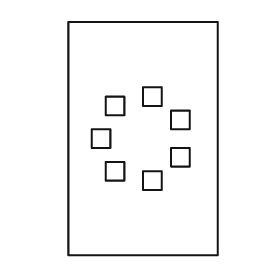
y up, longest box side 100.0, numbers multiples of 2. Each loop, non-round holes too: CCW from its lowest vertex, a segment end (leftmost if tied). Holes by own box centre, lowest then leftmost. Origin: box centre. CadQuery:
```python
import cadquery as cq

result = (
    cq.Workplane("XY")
    .moveTo(-32.0, -50.0)
    .lineTo(32.0, -50.0)
    .lineTo(32.0, 50.0)
    .lineTo(-32.0, 50.0)
    .close()
    .moveTo(0.0, -22.0)
    .lineTo(8.0, -22.0)
    .lineTo(8.0, -14.0)
    .lineTo(0.0, -14.0)
    .close()
    .moveTo(-16.0, -18.0)
    .lineTo(-8.0, -18.0)
    .lineTo(-8.0, -10.0)
    .lineTo(-16.0, -10.0)
    .close()
    .moveTo(12.0, -12.0)
    .lineTo(20.0, -12.0)
    .lineTo(20.0, -4.0)
    .lineTo(12.0, -4.0)
    .close()
    .moveTo(-22.0, -4.0)
    .lineTo(-14.0, -4.0)
    .lineTo(-14.0, 4.0)
    .lineTo(-22.0, 4.0)
    .close()
    .moveTo(12.0, 4.0)
    .lineTo(20.0, 4.0)
    .lineTo(20.0, 12.0)
    .lineTo(12.0, 12.0)
    .close()
    .moveTo(-16.0, 10.0)
    .lineTo(-8.0, 10.0)
    .lineTo(-8.0, 18.0)
    .lineTo(-16.0, 18.0)
    .close()
    .moveTo(0.0, 14.0)
    .lineTo(8.0, 14.0)
    .lineTo(8.0, 22.0)
    .lineTo(0.0, 22.0)
    .close()
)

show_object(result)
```